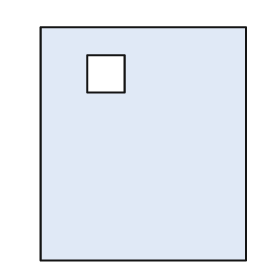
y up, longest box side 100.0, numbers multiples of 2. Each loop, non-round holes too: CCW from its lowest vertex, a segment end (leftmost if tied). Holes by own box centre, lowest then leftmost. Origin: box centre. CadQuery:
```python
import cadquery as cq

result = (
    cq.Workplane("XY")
    .moveTo(-44.0, -50.0)
    .lineTo(44.0, -50.0)
    .lineTo(44.0, 50.0)
    .lineTo(-44.0, 50.0)
    .close()
    .moveTo(-24.0, 22.0)
    .lineTo(-8.0, 22.0)
    .lineTo(-8.0, 38.0)
    .lineTo(-24.0, 38.0)
    .close()
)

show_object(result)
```